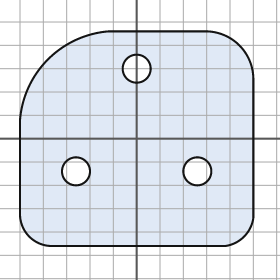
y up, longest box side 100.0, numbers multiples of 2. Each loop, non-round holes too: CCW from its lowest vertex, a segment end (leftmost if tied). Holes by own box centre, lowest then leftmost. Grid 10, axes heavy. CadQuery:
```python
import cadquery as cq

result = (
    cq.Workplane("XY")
    .moveTo(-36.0, -46.0)
    .lineTo(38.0, -46.0)
    .threePointArc((46.0, -42.0), (50.0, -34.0))
    .lineTo(50.0, 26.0)
    .threePointArc((44.0, 40.0), (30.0, 46.0))
    .lineTo(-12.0, 46.0)
    .threePointArc((-38.0, 34.0), (-50.0, 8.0))
    .lineTo(-50.0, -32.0)
    .threePointArc((-46.0, -42.0), (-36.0, -46.0))
    .close()
    .moveTo(-26.0, -14.0)
    .circle(6.0)
    .moveTo(26.0, -14.0)
    .circle(6.0)
    .moveTo(0.0, 30.0)
    .circle(6.0)
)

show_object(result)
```